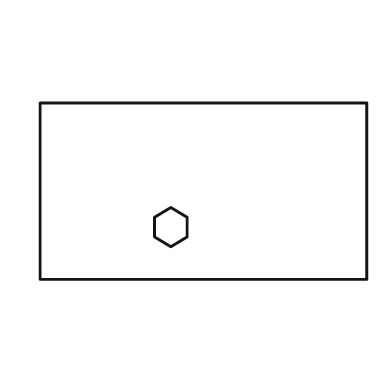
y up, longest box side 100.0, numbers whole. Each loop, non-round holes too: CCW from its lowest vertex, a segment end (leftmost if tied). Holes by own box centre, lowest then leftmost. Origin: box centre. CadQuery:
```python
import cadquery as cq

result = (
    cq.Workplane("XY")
    .moveTo(-50.0, -27.0)
    .lineTo(50.0, -27.0)
    .lineTo(50.0, 27.0)
    .lineTo(-50.0, 27.0)
    .close()
    .moveTo(-10.0, -17.0)
    .lineTo(-5.0, -14.0)
    .lineTo(-5.0, -8.0)
    .lineTo(-10.0, -5.0)
    .lineTo(-15.0, -8.0)
    .lineTo(-15.0, -14.0)
    .close()
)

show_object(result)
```